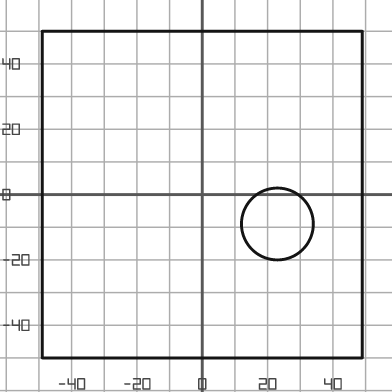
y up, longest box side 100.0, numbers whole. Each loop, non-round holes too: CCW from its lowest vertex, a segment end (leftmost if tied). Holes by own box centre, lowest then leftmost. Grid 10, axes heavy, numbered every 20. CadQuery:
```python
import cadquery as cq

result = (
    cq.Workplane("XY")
    .moveTo(-49.0, -50.0)
    .lineTo(49.0, -50.0)
    .lineTo(49.0, 50.0)
    .lineTo(-49.0, 50.0)
    .close()
    .moveTo(23.0, -9.0)
    .circle(11.0)
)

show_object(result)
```